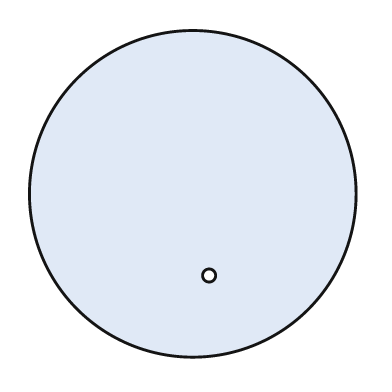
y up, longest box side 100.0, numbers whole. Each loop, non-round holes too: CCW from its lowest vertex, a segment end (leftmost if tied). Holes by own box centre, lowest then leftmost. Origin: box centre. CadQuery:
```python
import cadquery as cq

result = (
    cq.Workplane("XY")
    .moveTo(0.0, 0.0)
    .circle(50.0)
    .moveTo(5.0, -25.0)
    .circle(2.0)
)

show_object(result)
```